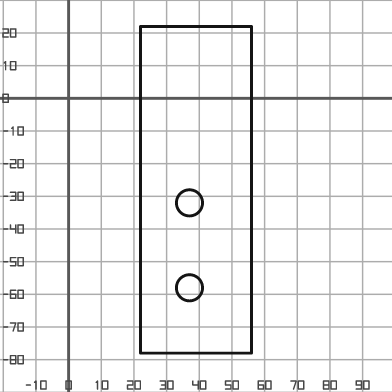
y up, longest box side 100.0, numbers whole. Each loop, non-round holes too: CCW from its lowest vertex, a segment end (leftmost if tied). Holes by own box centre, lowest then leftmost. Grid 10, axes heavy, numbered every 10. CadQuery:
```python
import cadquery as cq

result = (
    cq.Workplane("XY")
    .moveTo(22.0, -78.0)
    .lineTo(56.0, -78.0)
    .lineTo(56.0, 22.0)
    .lineTo(22.0, 22.0)
    .close()
    .moveTo(37.0, -58.0)
    .circle(4.0)
    .moveTo(37.0, -32.0)
    .circle(4.0)
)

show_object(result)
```